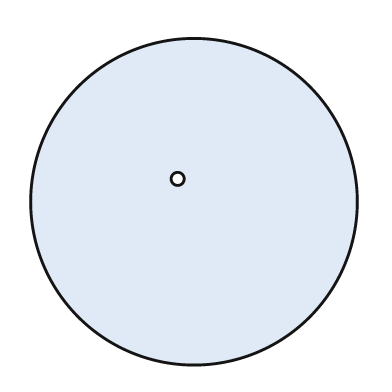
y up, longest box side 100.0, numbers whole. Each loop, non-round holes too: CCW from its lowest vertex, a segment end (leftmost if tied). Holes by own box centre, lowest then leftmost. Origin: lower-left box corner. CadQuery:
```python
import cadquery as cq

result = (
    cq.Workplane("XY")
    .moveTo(50.0, 50.0)
    .circle(50.0)
    .moveTo(45.0, 57.0)
    .circle(2.0)
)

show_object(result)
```